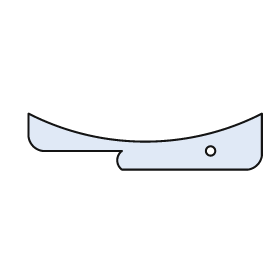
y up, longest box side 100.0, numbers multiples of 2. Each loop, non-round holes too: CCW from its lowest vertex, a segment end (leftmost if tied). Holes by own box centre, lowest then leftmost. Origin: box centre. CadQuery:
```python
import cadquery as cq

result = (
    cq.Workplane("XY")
    .moveTo(-10.0, -12.0)
    .lineTo(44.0, -12.0)
    .threePointArc((48.0, -10.0), (50.0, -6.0))
    .lineTo(50.0, 12.0)
    .threePointArc((0.0, 0.0), (-50.0, 12.0))
    .lineTo(-50.0, 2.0)
    .threePointArc((-48.0, -2.0), (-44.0, -4.0))
    .lineTo(-10.0, -4.0)
    .threePointArc((-12.0, -8.0), (-10.0, -12.0))
    .close()
    .moveTo(28.0, -4.0)
    .circle(2.0)
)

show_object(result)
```